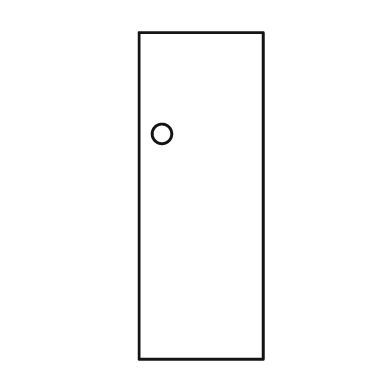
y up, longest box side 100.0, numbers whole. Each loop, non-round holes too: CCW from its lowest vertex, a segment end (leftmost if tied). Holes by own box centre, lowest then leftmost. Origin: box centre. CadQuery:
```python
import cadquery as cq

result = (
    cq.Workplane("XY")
    .moveTo(-19.0, -50.0)
    .lineTo(19.0, -50.0)
    .lineTo(19.0, 50.0)
    .lineTo(-19.0, 50.0)
    .close()
    .moveTo(-12.0, 19.0)
    .circle(3.0)
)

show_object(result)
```